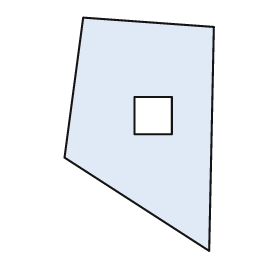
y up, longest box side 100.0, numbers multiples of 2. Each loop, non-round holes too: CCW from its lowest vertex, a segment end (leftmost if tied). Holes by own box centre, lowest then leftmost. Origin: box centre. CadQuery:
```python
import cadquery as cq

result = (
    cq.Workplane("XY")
    .moveTo(30.0, -50.0)
    .lineTo(32.0, 46.0)
    .lineTo(-24.0, 50.0)
    .lineTo(-32.0, -10.0)
    .close()
    .moveTo(-2.0, 0.0)
    .lineTo(14.0, 0.0)
    .lineTo(14.0, 16.0)
    .lineTo(-2.0, 16.0)
    .close()
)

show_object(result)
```